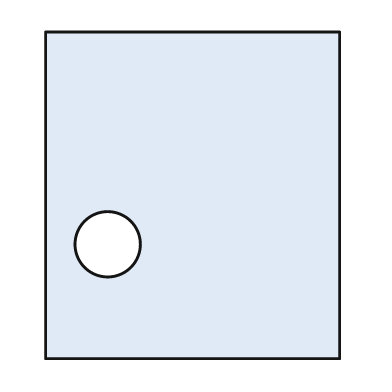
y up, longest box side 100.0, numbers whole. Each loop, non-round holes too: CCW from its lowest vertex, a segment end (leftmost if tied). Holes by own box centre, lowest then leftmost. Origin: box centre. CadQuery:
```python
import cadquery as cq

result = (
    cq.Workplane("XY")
    .moveTo(-45.0, -50.0)
    .lineTo(45.0, -50.0)
    .lineTo(45.0, 50.0)
    .lineTo(-45.0, 50.0)
    .close()
    .moveTo(-26.0, -15.0)
    .circle(10.0)
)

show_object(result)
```